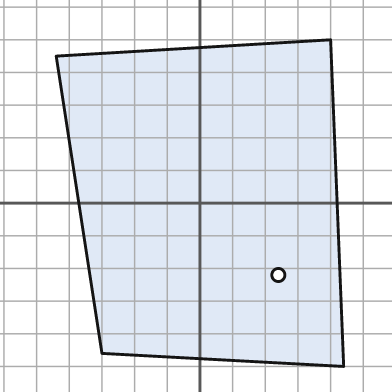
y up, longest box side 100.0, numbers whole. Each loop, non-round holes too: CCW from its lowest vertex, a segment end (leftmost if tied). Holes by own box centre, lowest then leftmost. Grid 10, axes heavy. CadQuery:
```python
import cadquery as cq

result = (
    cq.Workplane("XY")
    .moveTo(44.0, -50.0)
    .lineTo(40.0, 50.0)
    .lineTo(-44.0, 45.0)
    .lineTo(-30.0, -46.0)
    .close()
    .moveTo(24.0, -22.0)
    .circle(2.0)
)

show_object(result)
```